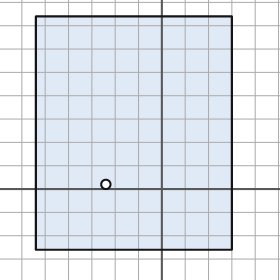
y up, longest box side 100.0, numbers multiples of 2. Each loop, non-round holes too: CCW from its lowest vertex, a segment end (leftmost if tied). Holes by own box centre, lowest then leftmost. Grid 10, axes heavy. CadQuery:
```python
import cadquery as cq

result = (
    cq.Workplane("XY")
    .moveTo(-54.0, -26.0)
    .lineTo(30.0, -26.0)
    .lineTo(30.0, 74.0)
    .lineTo(-54.0, 74.0)
    .close()
    .moveTo(-24.0, 2.0)
    .circle(2.0)
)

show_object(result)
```